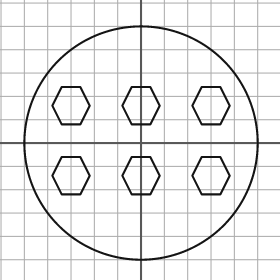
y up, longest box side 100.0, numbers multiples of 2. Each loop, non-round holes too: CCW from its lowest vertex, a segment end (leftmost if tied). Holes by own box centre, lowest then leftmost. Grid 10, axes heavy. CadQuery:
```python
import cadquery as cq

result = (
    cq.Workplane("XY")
    .moveTo(0.0, 0.0)
    .circle(50.0)
    .moveTo(-34.0, -22.0)
    .lineTo(-26.0, -22.0)
    .lineTo(-22.0, -14.0)
    .lineTo(-26.0, -6.0)
    .lineTo(-34.0, -6.0)
    .lineTo(-38.0, -14.0)
    .close()
    .moveTo(-4.0, -22.0)
    .lineTo(4.0, -22.0)
    .lineTo(8.0, -14.0)
    .lineTo(4.0, -6.0)
    .lineTo(-4.0, -6.0)
    .lineTo(-8.0, -14.0)
    .close()
    .moveTo(26.0, -22.0)
    .lineTo(34.0, -22.0)
    .lineTo(38.0, -14.0)
    .lineTo(34.0, -6.0)
    .lineTo(26.0, -6.0)
    .lineTo(22.0, -14.0)
    .close()
    .moveTo(-34.0, 8.0)
    .lineTo(-26.0, 8.0)
    .lineTo(-22.0, 16.0)
    .lineTo(-26.0, 24.0)
    .lineTo(-34.0, 24.0)
    .lineTo(-38.0, 16.0)
    .close()
    .moveTo(-4.0, 8.0)
    .lineTo(4.0, 8.0)
    .lineTo(8.0, 16.0)
    .lineTo(4.0, 24.0)
    .lineTo(-4.0, 24.0)
    .lineTo(-8.0, 16.0)
    .close()
    .moveTo(26.0, 8.0)
    .lineTo(34.0, 8.0)
    .lineTo(38.0, 16.0)
    .lineTo(34.0, 24.0)
    .lineTo(26.0, 24.0)
    .lineTo(22.0, 16.0)
    .close()
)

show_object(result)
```